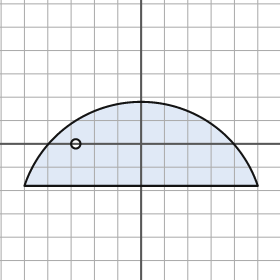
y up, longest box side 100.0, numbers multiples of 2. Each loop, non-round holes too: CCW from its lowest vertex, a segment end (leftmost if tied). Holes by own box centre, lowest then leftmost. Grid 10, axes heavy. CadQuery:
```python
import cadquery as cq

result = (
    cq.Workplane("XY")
    .moveTo(-50.0, -18.0)
    .lineTo(50.0, -18.0)
    .threePointArc((0.0, 18.0), (-50.0, -18.0))
    .close()
    .moveTo(-28.0, 0.0)
    .circle(2.0)
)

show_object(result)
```